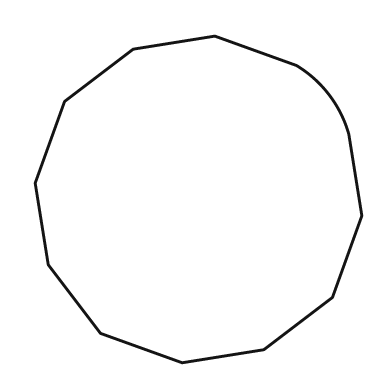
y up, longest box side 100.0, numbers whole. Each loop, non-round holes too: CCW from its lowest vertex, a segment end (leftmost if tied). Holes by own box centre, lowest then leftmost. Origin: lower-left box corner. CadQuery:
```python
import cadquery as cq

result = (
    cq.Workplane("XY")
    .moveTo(45.0, 0.0)
    .lineTo(70.0, 4.0)
    .lineTo(91.0, 20.0)
    .lineTo(100.0, 45.0)
    .lineTo(96.0, 70.0)
    .threePointArc((90.0, 82.0), (80.0, 91.0))
    .lineTo(55.0, 100.0)
    .lineTo(30.0, 96.0)
    .lineTo(9.0, 80.0)
    .lineTo(0.0, 55.0)
    .lineTo(4.0, 30.0)
    .lineTo(20.0, 9.0)
    .close()
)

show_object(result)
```